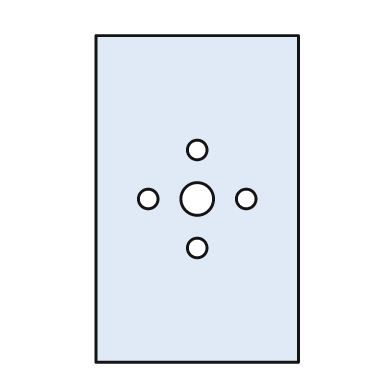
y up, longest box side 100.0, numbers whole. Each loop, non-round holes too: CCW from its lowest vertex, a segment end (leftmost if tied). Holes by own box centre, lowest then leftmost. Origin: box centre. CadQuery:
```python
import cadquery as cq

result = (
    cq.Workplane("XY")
    .moveTo(-31.0, -50.0)
    .lineTo(31.0, -50.0)
    .lineTo(31.0, 50.0)
    .lineTo(-31.0, 50.0)
    .close()
    .moveTo(0.0, -15.0)
    .circle(3.0)
    .moveTo(-15.0, 0.0)
    .circle(3.0)
    .moveTo(0.0, 0.0)
    .circle(5.0)
    .moveTo(15.0, 0.0)
    .circle(3.0)
    .moveTo(0.0, 15.0)
    .circle(3.0)
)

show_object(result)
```